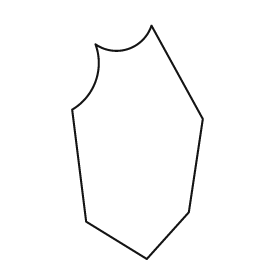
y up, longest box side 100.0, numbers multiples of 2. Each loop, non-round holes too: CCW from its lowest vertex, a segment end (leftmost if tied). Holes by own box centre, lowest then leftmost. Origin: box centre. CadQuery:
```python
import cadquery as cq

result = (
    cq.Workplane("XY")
    .moveTo(4.0, -50.0)
    .lineTo(22.0, -30.0)
    .lineTo(28.0, 10.0)
    .lineTo(6.0, 50.0)
    .threePointArc((-4.0, 40.0), (-18.0, 42.0))
    .threePointArc((-18.0, 26.0), (-28.0, 14.0))
    .lineTo(-22.0, -34.0)
    .close()
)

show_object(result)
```